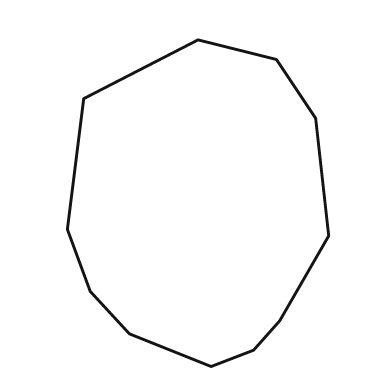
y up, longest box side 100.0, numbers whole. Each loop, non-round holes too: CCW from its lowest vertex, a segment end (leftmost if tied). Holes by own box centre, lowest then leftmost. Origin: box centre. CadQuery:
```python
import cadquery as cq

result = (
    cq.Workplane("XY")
    .moveTo(4.0, -50.0)
    .lineTo(17.0, -45.0)
    .lineTo(25.0, -36.0)
    .lineTo(40.0, -10.0)
    .lineTo(36.0, 26.0)
    .lineTo(24.0, 44.0)
    .lineTo(0.0, 50.0)
    .lineTo(-35.0, 32.0)
    .lineTo(-40.0, -8.0)
    .lineTo(-33.0, -27.0)
    .lineTo(-21.0, -40.0)
    .close()
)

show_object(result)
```